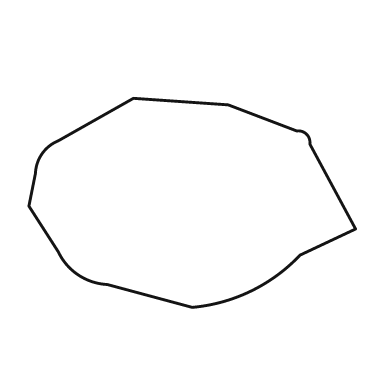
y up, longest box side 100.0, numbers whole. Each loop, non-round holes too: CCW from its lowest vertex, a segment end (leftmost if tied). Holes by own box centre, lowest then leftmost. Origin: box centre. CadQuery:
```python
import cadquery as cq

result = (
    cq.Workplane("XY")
    .moveTo(0.0, -32.0)
    .threePointArc((18.0, -27.0), (33.0, -16.0))
    .lineTo(50.0, -8.0)
    .lineTo(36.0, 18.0)
    .threePointArc((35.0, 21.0), (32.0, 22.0))
    .lineTo(11.0, 30.0)
    .lineTo(-18.0, 32.0)
    .lineTo(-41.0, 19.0)
    .threePointArc((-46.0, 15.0), (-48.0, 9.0))
    .lineTo(-50.0, -1.0)
    .lineTo(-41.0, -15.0)
    .threePointArc((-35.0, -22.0), (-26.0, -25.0))
    .close()
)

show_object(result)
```